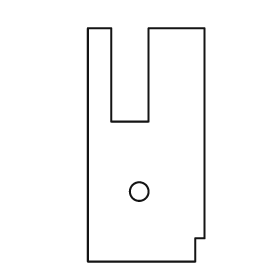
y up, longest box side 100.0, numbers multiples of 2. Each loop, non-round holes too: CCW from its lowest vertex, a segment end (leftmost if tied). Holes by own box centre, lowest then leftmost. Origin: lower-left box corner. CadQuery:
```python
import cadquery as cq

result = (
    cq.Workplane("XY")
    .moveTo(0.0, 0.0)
    .lineTo(46.0, 0.0)
    .lineTo(46.0, 10.0)
    .lineTo(50.0, 10.0)
    .lineTo(50.0, 100.0)
    .lineTo(26.0, 100.0)
    .lineTo(26.0, 60.0)
    .lineTo(10.0, 60.0)
    .lineTo(10.0, 100.0)
    .lineTo(0.0, 100.0)
    .close()
    .moveTo(22.0, 30.0)
    .circle(4.0)
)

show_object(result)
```